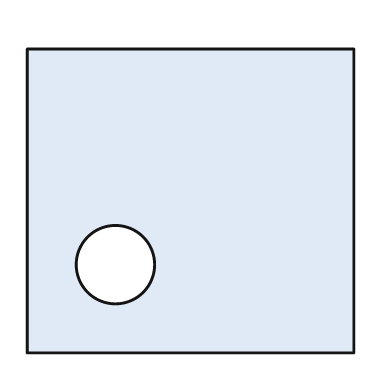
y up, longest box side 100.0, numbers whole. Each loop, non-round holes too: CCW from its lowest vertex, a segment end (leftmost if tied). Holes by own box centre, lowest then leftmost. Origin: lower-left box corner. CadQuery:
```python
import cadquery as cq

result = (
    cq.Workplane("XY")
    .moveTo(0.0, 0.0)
    .lineTo(100.0, 0.0)
    .lineTo(100.0, 93.0)
    .lineTo(0.0, 93.0)
    .close()
    .moveTo(27.0, 27.0)
    .circle(12.0)
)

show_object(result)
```